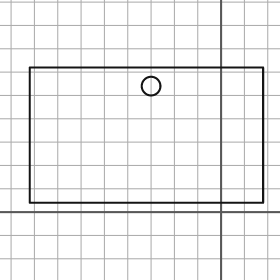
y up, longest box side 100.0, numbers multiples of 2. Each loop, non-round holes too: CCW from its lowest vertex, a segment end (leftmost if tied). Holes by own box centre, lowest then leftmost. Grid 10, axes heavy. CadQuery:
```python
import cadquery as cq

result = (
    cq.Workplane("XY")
    .moveTo(-82.0, 4.0)
    .lineTo(18.0, 4.0)
    .lineTo(18.0, 62.0)
    .lineTo(-82.0, 62.0)
    .close()
    .moveTo(-30.0, 54.0)
    .circle(4.0)
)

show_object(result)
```